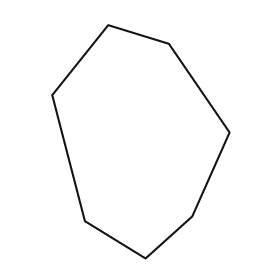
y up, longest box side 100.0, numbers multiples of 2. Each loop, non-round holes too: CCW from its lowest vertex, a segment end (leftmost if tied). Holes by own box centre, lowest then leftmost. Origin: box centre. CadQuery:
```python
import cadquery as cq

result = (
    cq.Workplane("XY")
    .moveTo(2.0, -50.0)
    .lineTo(22.0, -32.0)
    .lineTo(38.0, 4.0)
    .lineTo(12.0, 42.0)
    .lineTo(-14.0, 50.0)
    .lineTo(-38.0, 20.0)
    .lineTo(-24.0, -34.0)
    .close()
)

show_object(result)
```